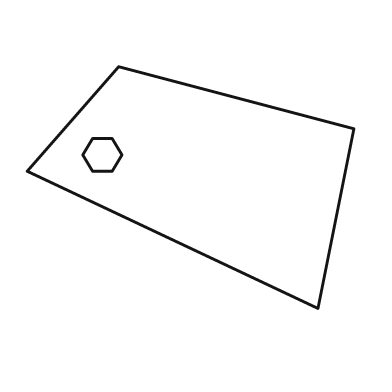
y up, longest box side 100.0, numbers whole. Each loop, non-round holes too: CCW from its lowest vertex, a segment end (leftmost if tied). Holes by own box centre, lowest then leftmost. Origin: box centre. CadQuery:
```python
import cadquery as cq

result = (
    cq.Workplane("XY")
    .moveTo(39.0, -37.0)
    .lineTo(50.0, 18.0)
    .lineTo(-22.0, 37.0)
    .lineTo(-50.0, 5.0)
    .close()
    .moveTo(-30.0, 5.0)
    .lineTo(-24.0, 5.0)
    .lineTo(-21.0, 10.0)
    .lineTo(-24.0, 15.0)
    .lineTo(-30.0, 15.0)
    .lineTo(-33.0, 10.0)
    .close()
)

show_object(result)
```